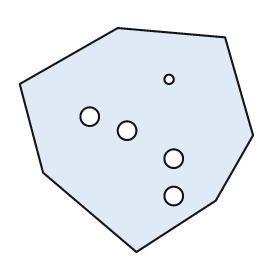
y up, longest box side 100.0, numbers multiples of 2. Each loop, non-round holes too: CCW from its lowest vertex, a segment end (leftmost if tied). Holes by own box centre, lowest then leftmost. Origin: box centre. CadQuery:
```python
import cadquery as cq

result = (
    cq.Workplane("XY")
    .moveTo(0.0, -48.0)
    .lineTo(34.0, -26.0)
    .lineTo(50.0, 2.0)
    .lineTo(38.0, 44.0)
    .lineTo(-8.0, 48.0)
    .lineTo(-50.0, 24.0)
    .lineTo(-40.0, -14.0)
    .close()
    .moveTo(16.0, -24.0)
    .circle(4.0)
    .moveTo(16.0, -8.0)
    .circle(4.0)
    .moveTo(-4.0, 4.0)
    .circle(4.0)
    .moveTo(-20.0, 10.0)
    .circle(4.0)
    .moveTo(14.0, 26.0)
    .circle(2.0)
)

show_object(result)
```